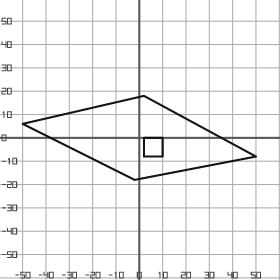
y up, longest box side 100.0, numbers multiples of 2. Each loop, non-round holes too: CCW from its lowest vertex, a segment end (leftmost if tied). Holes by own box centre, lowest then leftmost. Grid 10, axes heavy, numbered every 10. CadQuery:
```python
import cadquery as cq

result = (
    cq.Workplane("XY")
    .moveTo(-2.0, -18.0)
    .lineTo(50.0, -8.0)
    .lineTo(2.0, 18.0)
    .lineTo(-50.0, 6.0)
    .close()
    .moveTo(2.0, -8.0)
    .lineTo(10.0, -8.0)
    .lineTo(10.0, 0.0)
    .lineTo(2.0, 0.0)
    .close()
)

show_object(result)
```